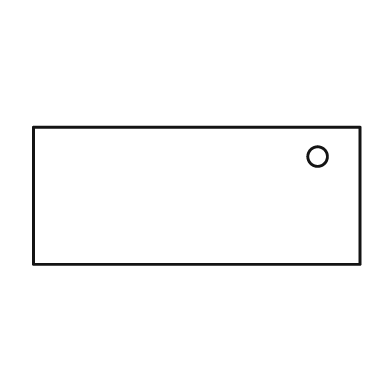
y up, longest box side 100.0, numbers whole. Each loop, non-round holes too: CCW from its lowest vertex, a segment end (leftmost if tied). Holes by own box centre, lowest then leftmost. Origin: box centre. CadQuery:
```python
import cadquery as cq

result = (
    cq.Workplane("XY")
    .moveTo(-50.0, -21.0)
    .lineTo(50.0, -21.0)
    .lineTo(50.0, 21.0)
    .lineTo(-50.0, 21.0)
    .close()
    .moveTo(37.0, 12.0)
    .circle(3.0)
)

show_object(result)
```